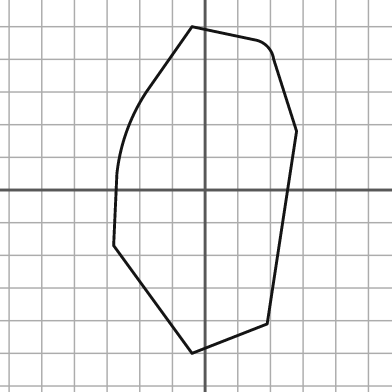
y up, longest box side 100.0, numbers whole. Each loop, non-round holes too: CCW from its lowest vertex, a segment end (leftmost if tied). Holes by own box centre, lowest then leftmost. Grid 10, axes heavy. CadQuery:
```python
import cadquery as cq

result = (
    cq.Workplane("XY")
    .moveTo(-4.0, -50.0)
    .lineTo(19.0, -41.0)
    .lineTo(28.0, 18.0)
    .lineTo(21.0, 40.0)
    .threePointArc((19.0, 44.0), (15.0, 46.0))
    .lineTo(-4.0, 50.0)
    .lineTo(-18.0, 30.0)
    .threePointArc((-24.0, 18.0), (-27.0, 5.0))
    .lineTo(-28.0, -17.0)
    .close()
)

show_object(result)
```